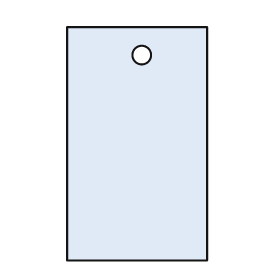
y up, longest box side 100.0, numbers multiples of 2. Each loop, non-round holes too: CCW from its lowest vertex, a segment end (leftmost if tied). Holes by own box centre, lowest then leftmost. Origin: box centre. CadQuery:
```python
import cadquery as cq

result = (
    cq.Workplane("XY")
    .moveTo(-30.0, -50.0)
    .lineTo(30.0, -50.0)
    .lineTo(30.0, 50.0)
    .lineTo(-30.0, 50.0)
    .close()
    .moveTo(2.0, 38.0)
    .circle(4.0)
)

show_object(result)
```